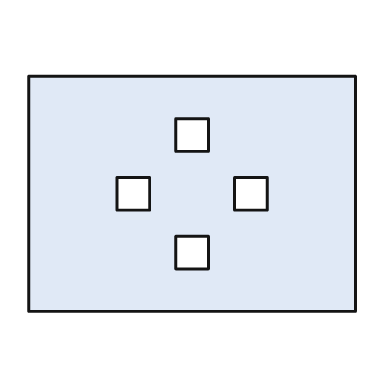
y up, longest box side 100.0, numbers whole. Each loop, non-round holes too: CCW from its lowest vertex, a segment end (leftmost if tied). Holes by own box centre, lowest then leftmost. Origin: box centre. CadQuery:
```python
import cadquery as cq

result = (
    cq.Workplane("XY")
    .moveTo(-50.0, -36.0)
    .lineTo(50.0, -36.0)
    .lineTo(50.0, 36.0)
    .lineTo(-50.0, 36.0)
    .close()
    .moveTo(-5.0, -23.0)
    .lineTo(5.0, -23.0)
    .lineTo(5.0, -13.0)
    .lineTo(-5.0, -13.0)
    .close()
    .moveTo(-23.0, -5.0)
    .lineTo(-13.0, -5.0)
    .lineTo(-13.0, 5.0)
    .lineTo(-23.0, 5.0)
    .close()
    .moveTo(13.0, -5.0)
    .lineTo(23.0, -5.0)
    .lineTo(23.0, 5.0)
    .lineTo(13.0, 5.0)
    .close()
    .moveTo(-5.0, 13.0)
    .lineTo(5.0, 13.0)
    .lineTo(5.0, 23.0)
    .lineTo(-5.0, 23.0)
    .close()
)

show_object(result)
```